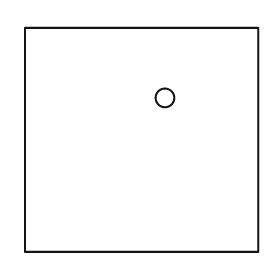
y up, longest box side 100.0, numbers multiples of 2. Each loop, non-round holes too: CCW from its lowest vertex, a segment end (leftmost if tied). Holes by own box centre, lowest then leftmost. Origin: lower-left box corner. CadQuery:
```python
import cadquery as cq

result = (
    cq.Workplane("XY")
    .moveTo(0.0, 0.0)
    .lineTo(100.0, 0.0)
    .lineTo(100.0, 96.0)
    .lineTo(0.0, 96.0)
    .close()
    .moveTo(60.0, 66.0)
    .circle(4.0)
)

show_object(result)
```